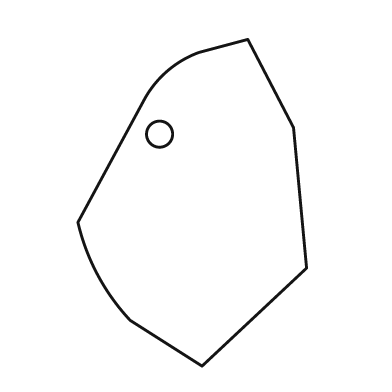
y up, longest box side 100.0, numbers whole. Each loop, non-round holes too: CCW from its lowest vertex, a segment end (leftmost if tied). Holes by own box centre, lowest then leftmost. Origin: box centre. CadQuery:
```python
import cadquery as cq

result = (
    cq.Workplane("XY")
    .moveTo(3.0, -50.0)
    .lineTo(35.0, -20.0)
    .lineTo(31.0, 23.0)
    .lineTo(17.0, 50.0)
    .lineTo(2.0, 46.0)
    .threePointArc((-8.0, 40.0), (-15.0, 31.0))
    .lineTo(-35.0, -6.0)
    .threePointArc((-29.0, -22.0), (-19.0, -36.0))
    .close()
    .moveTo(-10.0, 21.0)
    .circle(4.0)
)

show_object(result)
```